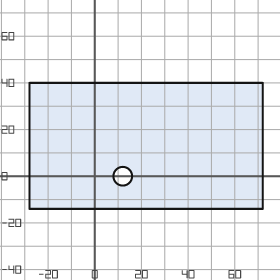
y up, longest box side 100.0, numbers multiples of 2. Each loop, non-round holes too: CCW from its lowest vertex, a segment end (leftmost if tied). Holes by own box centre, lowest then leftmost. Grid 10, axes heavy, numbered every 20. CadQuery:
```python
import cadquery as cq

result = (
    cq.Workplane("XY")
    .moveTo(-28.0, -14.0)
    .lineTo(72.0, -14.0)
    .lineTo(72.0, 40.0)
    .lineTo(-28.0, 40.0)
    .close()
    .moveTo(12.0, 0.0)
    .circle(4.0)
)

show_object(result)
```